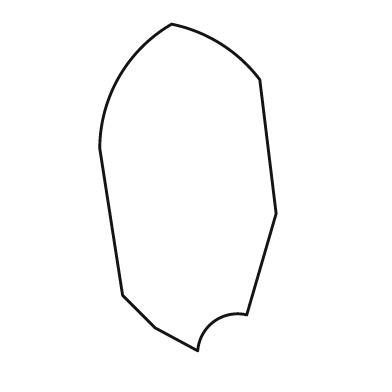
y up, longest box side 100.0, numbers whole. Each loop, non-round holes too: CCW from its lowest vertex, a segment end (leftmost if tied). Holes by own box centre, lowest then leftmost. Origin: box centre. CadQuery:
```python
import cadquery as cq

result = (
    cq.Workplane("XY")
    .moveTo(3.0, -50.0)
    .threePointArc((8.0, -41.0), (18.0, -39.0))
    .lineTo(27.0, -8.0)
    .lineTo(22.0, 33.0)
    .threePointArc((10.0, 44.0), (-5.0, 50.0))
    .threePointArc((-21.0, 34.0), (-27.0, 12.0))
    .lineTo(-20.0, -33.0)
    .lineTo(-10.0, -43.0)
    .close()
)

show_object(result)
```